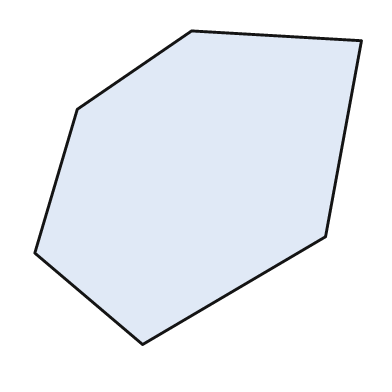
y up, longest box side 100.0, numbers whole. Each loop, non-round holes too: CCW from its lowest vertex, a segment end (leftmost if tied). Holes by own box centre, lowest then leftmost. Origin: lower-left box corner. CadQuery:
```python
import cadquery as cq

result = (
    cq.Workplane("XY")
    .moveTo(33.0, 0.0)
    .lineTo(89.0, 33.0)
    .lineTo(100.0, 93.0)
    .lineTo(48.0, 96.0)
    .lineTo(13.0, 72.0)
    .lineTo(0.0, 28.0)
    .close()
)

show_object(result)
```